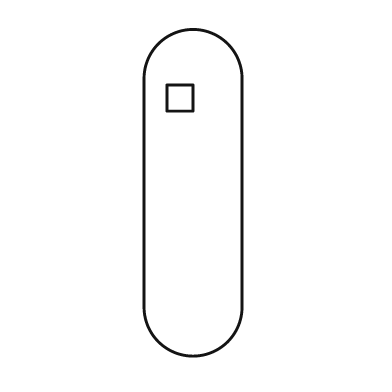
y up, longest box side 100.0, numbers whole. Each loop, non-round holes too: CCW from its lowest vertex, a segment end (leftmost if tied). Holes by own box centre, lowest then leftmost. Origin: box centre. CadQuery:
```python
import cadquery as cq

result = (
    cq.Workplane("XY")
    .moveTo(-15.0, -35.0)
    .threePointArc((0.0, -50.0), (15.0, -35.0))
    .lineTo(15.0, 35.0)
    .threePointArc((0.0, 50.0), (-15.0, 35.0))
    .close()
    .moveTo(-8.0, 25.0)
    .lineTo(0.0, 25.0)
    .lineTo(0.0, 33.0)
    .lineTo(-8.0, 33.0)
    .close()
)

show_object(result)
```